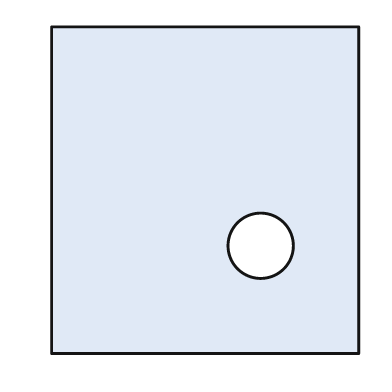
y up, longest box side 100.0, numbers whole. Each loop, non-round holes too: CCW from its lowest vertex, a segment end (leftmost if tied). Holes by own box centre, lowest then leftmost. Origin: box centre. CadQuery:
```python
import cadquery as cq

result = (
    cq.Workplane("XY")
    .moveTo(-47.0, -50.0)
    .lineTo(47.0, -50.0)
    .lineTo(47.0, 50.0)
    .lineTo(-47.0, 50.0)
    .close()
    .moveTo(17.0, -17.0)
    .circle(10.0)
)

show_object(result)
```